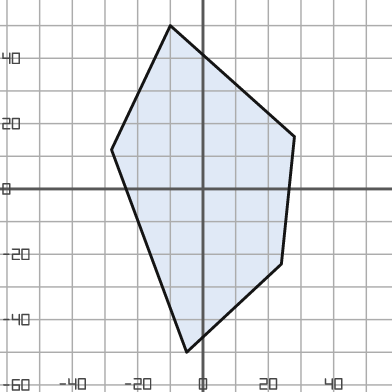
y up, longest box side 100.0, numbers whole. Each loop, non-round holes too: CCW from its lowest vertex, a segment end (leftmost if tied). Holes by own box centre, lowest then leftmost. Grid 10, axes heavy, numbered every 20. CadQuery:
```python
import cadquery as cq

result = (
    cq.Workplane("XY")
    .moveTo(-5.0, -50.0)
    .lineTo(24.0, -23.0)
    .lineTo(28.0, 16.0)
    .lineTo(-10.0, 50.0)
    .lineTo(-28.0, 12.0)
    .close()
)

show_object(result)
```